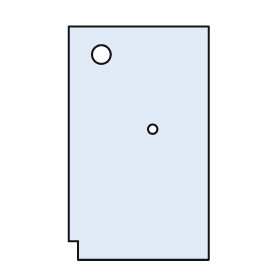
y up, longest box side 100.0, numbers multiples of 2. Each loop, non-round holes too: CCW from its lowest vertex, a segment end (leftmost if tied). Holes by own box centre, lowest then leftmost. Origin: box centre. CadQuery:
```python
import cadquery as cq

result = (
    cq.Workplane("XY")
    .moveTo(-26.0, -50.0)
    .lineTo(30.0, -50.0)
    .lineTo(30.0, 50.0)
    .lineTo(-30.0, 50.0)
    .lineTo(-30.0, -42.0)
    .lineTo(-26.0, -42.0)
    .close()
    .moveTo(6.0, 6.0)
    .circle(2.0)
    .moveTo(-16.0, 38.0)
    .circle(4.0)
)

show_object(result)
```